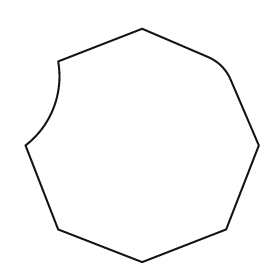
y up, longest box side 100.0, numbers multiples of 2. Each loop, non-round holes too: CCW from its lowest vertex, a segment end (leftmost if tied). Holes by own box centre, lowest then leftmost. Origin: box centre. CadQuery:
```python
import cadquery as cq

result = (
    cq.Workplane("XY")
    .moveTo(0.0, -50.0)
    .lineTo(36.0, -36.0)
    .lineTo(50.0, 0.0)
    .lineTo(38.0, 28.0)
    .threePointArc((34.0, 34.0), (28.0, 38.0))
    .lineTo(0.0, 50.0)
    .lineTo(-36.0, 36.0)
    .threePointArc((-38.0, 16.0), (-50.0, 0.0))
    .lineTo(-36.0, -36.0)
    .close()
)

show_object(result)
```